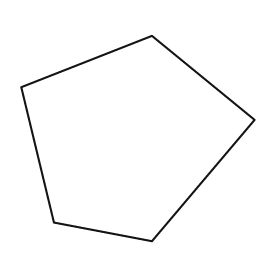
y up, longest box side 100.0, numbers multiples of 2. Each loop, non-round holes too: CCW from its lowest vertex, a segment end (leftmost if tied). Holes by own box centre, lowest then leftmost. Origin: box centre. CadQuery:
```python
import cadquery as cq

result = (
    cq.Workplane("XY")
    .moveTo(6.0, -44.0)
    .lineTo(50.0, 8.0)
    .lineTo(6.0, 44.0)
    .lineTo(-50.0, 22.0)
    .lineTo(-36.0, -36.0)
    .close()
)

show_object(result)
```